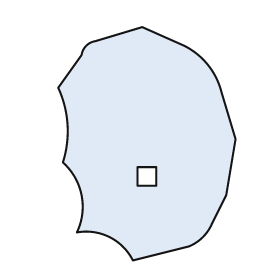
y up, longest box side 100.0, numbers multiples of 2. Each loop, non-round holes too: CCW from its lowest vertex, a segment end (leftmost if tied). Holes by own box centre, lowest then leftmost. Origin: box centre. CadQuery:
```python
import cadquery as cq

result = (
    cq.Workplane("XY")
    .moveTo(-6.0, -50.0)
    .lineTo(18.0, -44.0)
    .threePointArc((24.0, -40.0), (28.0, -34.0))
    .lineTo(34.0, -22.0)
    .lineTo(38.0, 2.0)
    .lineTo(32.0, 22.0)
    .threePointArc((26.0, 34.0), (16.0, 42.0))
    .lineTo(-2.0, 50.0)
    .lineTo(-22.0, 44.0)
    .threePointArc((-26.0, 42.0), (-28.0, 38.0))
    .lineTo(-38.0, 24.0)
    .threePointArc((-34.0, 8.0), (-36.0, -8.0))
    .threePointArc((-28.0, -22.0), (-30.0, -38.0))
    .threePointArc((-16.0, -40.0), (-6.0, -50.0))
    .close()
    .moveTo(-4.0, -18.0)
    .lineTo(4.0, -18.0)
    .lineTo(4.0, -10.0)
    .lineTo(-4.0, -10.0)
    .close()
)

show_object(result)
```